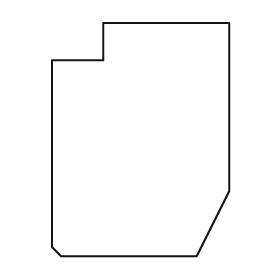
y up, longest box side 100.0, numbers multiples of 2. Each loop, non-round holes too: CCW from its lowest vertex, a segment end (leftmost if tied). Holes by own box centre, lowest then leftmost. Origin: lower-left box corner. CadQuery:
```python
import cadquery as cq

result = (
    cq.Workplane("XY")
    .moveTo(4.0, 0.0)
    .lineTo(62.0, 0.0)
    .lineTo(76.0, 28.0)
    .lineTo(76.0, 100.0)
    .lineTo(22.0, 100.0)
    .lineTo(22.0, 84.0)
    .lineTo(0.0, 84.0)
    .lineTo(0.0, 4.0)
    .close()
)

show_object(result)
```